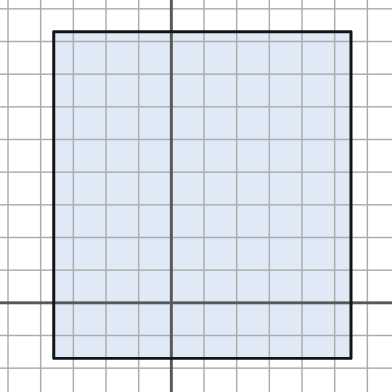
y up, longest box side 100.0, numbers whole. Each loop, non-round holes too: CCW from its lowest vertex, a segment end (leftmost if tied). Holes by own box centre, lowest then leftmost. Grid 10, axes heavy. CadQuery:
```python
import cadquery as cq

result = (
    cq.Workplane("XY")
    .moveTo(-36.0, -17.0)
    .lineTo(55.0, -17.0)
    .lineTo(55.0, 83.0)
    .lineTo(-36.0, 83.0)
    .close()
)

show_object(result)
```